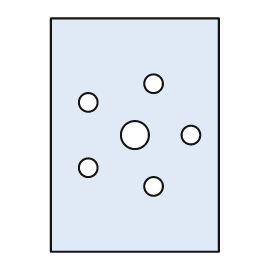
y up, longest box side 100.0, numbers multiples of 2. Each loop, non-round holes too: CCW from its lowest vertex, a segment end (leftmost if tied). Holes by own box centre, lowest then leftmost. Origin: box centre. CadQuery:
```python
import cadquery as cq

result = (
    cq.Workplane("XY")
    .moveTo(-36.0, -50.0)
    .lineTo(36.0, -50.0)
    .lineTo(36.0, 50.0)
    .lineTo(-36.0, 50.0)
    .close()
    .moveTo(8.0, -22.0)
    .circle(4.0)
    .moveTo(-20.0, -14.0)
    .circle(4.0)
    .moveTo(0.0, 0.0)
    .circle(6.0)
    .moveTo(24.0, 0.0)
    .circle(4.0)
    .moveTo(-20.0, 14.0)
    .circle(4.0)
    .moveTo(8.0, 22.0)
    .circle(4.0)
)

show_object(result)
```